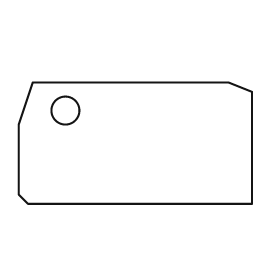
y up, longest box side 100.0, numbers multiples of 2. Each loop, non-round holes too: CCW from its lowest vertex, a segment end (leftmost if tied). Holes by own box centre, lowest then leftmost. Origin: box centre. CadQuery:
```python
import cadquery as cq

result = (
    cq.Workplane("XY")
    .moveTo(-46.0, -26.0)
    .lineTo(50.0, -26.0)
    .lineTo(50.0, 22.0)
    .lineTo(40.0, 26.0)
    .lineTo(-44.0, 26.0)
    .lineTo(-50.0, 8.0)
    .lineTo(-50.0, -22.0)
    .close()
    .moveTo(-30.0, 14.0)
    .circle(6.0)
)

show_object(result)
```